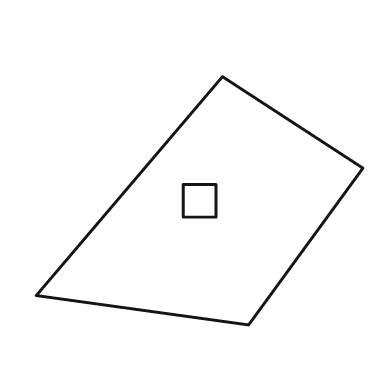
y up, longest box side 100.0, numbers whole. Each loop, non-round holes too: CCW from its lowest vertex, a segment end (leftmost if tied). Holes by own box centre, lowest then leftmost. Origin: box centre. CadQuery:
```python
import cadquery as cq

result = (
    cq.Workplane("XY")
    .moveTo(15.0, -38.0)
    .lineTo(50.0, 10.0)
    .lineTo(7.0, 38.0)
    .lineTo(-50.0, -29.0)
    .close()
    .moveTo(-5.0, -5.0)
    .lineTo(5.0, -5.0)
    .lineTo(5.0, 5.0)
    .lineTo(-5.0, 5.0)
    .close()
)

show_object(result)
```